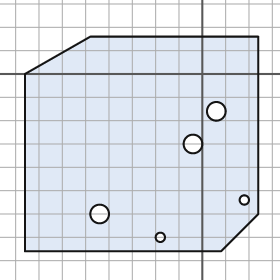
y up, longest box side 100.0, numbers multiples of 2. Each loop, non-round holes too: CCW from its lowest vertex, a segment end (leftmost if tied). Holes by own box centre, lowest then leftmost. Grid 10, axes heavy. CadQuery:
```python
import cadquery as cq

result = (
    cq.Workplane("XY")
    .moveTo(-76.0, -76.0)
    .lineTo(8.0, -76.0)
    .lineTo(24.0, -60.0)
    .lineTo(24.0, 16.0)
    .lineTo(-48.0, 16.0)
    .lineTo(-76.0, 0.0)
    .close()
    .moveTo(-18.0, -70.0)
    .circle(2.0)
    .moveTo(-44.0, -60.0)
    .circle(4.0)
    .moveTo(18.0, -54.0)
    .circle(2.0)
    .moveTo(-4.0, -30.0)
    .circle(4.0)
    .moveTo(6.0, -16.0)
    .circle(4.0)
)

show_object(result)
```